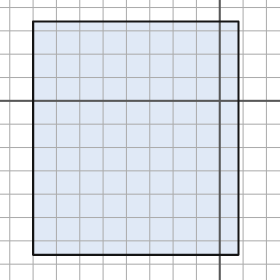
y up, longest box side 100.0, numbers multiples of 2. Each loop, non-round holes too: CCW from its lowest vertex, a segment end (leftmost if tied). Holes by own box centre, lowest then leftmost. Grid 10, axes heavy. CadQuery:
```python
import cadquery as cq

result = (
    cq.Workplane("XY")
    .moveTo(-80.0, -66.0)
    .lineTo(8.0, -66.0)
    .lineTo(8.0, 34.0)
    .lineTo(-80.0, 34.0)
    .close()
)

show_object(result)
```